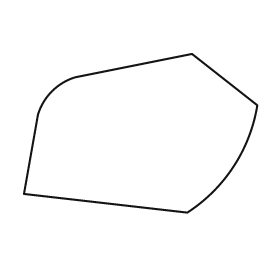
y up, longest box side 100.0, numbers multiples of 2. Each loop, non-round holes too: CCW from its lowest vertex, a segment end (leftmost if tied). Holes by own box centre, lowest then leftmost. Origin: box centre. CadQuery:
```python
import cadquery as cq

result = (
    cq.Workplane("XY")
    .moveTo(20.0, -34.0)
    .threePointArc((40.0, -14.0), (50.0, 12.0))
    .lineTo(22.0, 34.0)
    .lineTo(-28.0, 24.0)
    .threePointArc((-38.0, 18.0), (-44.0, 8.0))
    .lineTo(-50.0, -26.0)
    .close()
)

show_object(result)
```